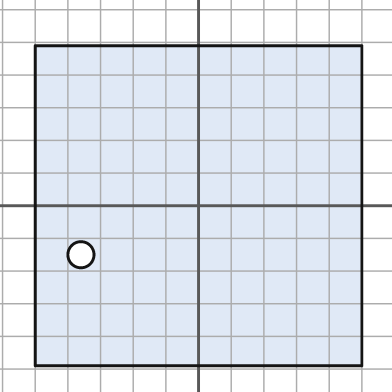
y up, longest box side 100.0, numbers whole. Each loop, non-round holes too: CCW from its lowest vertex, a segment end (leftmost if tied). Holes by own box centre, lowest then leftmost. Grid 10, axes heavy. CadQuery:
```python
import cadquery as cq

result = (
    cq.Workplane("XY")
    .moveTo(-50.0, -49.0)
    .lineTo(50.0, -49.0)
    .lineTo(50.0, 49.0)
    .lineTo(-50.0, 49.0)
    .close()
    .moveTo(-36.0, -15.0)
    .circle(4.0)
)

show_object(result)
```